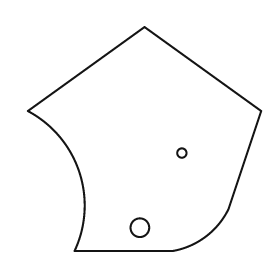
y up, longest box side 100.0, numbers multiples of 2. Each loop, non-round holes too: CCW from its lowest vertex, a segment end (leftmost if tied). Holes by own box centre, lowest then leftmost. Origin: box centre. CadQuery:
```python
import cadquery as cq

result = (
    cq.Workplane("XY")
    .moveTo(-30.0, -48.0)
    .lineTo(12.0, -48.0)
    .threePointArc((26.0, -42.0), (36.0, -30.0))
    .lineTo(50.0, 12.0)
    .lineTo(0.0, 48.0)
    .lineTo(-50.0, 12.0)
    .threePointArc((-28.0, -14.0), (-30.0, -48.0))
    .close()
    .moveTo(-2.0, -38.0)
    .circle(4.0)
    .moveTo(16.0, -6.0)
    .circle(2.0)
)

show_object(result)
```